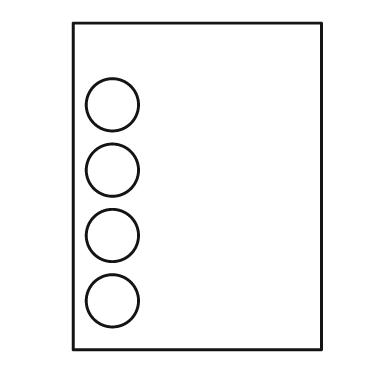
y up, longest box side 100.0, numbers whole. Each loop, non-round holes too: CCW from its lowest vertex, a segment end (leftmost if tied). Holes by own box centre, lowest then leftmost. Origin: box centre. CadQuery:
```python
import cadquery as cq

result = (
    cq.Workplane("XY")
    .moveTo(-38.0, -50.0)
    .lineTo(38.0, -50.0)
    .lineTo(38.0, 50.0)
    .lineTo(-38.0, 50.0)
    .close()
    .moveTo(-26.0, -35.0)
    .circle(8.0)
    .moveTo(-26.0, -15.0)
    .circle(8.0)
    .moveTo(-26.0, 5.0)
    .circle(8.0)
    .moveTo(-26.0, 25.0)
    .circle(8.0)
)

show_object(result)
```